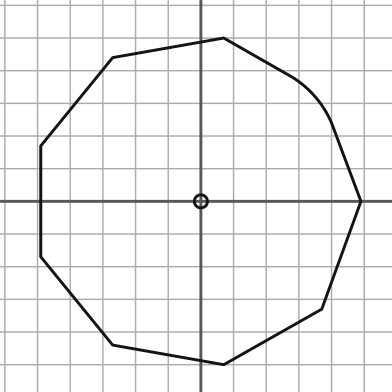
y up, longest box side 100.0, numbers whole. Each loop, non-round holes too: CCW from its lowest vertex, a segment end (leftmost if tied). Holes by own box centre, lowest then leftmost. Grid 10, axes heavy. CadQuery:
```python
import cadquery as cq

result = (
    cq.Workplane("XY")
    .moveTo(7.0, -50.0)
    .lineTo(37.0, -33.0)
    .lineTo(49.0, 0.0)
    .lineTo(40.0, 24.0)
    .threePointArc((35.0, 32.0), (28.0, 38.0))
    .lineTo(7.0, 50.0)
    .lineTo(-27.0, 44.0)
    .lineTo(-49.0, 17.0)
    .lineTo(-49.0, -17.0)
    .lineTo(-27.0, -44.0)
    .close()
    .moveTo(0.0, 0.0)
    .circle(2.0)
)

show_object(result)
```